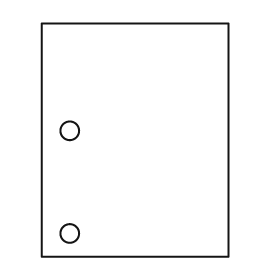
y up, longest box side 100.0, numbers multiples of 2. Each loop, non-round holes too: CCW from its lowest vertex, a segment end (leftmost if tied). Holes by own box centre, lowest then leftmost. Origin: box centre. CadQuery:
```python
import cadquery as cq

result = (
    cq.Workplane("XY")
    .moveTo(-40.0, -50.0)
    .lineTo(40.0, -50.0)
    .lineTo(40.0, 50.0)
    .lineTo(-40.0, 50.0)
    .close()
    .moveTo(-28.0, -40.0)
    .circle(4.0)
    .moveTo(-28.0, 4.0)
    .circle(4.0)
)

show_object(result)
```